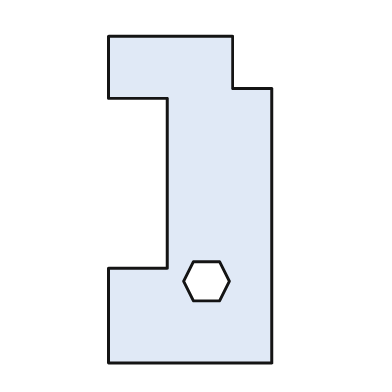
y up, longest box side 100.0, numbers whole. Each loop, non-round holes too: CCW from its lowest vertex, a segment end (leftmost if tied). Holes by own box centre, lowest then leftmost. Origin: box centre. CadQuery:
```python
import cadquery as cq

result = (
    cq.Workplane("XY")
    .moveTo(-25.0, -50.0)
    .lineTo(25.0, -50.0)
    .lineTo(25.0, 34.0)
    .lineTo(13.0, 34.0)
    .lineTo(13.0, 50.0)
    .lineTo(-25.0, 50.0)
    .lineTo(-25.0, 31.0)
    .lineTo(-7.0, 31.0)
    .lineTo(-7.0, -21.0)
    .lineTo(-25.0, -21.0)
    .close()
    .moveTo(1.0, -31.0)
    .lineTo(9.0, -31.0)
    .lineTo(12.0, -25.0)
    .lineTo(9.0, -19.0)
    .lineTo(1.0, -19.0)
    .lineTo(-2.0, -25.0)
    .close()
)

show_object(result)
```